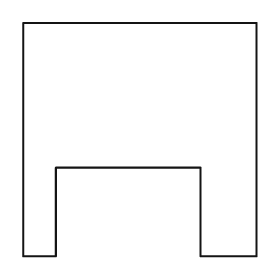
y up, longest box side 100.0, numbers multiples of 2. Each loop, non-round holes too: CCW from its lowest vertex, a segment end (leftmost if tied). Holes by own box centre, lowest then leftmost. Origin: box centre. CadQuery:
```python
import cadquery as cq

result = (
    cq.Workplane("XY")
    .moveTo(-50.0, -50.0)
    .lineTo(-36.0, -50.0)
    .lineTo(-36.0, -12.0)
    .lineTo(26.0, -12.0)
    .lineTo(26.0, -50.0)
    .lineTo(50.0, -50.0)
    .lineTo(50.0, 50.0)
    .lineTo(-50.0, 50.0)
    .close()
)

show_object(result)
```